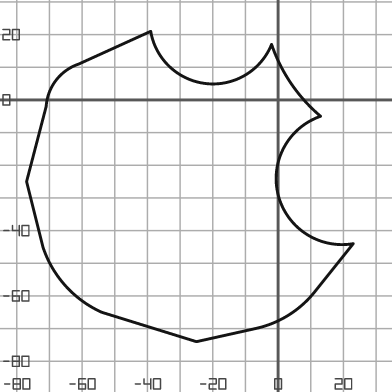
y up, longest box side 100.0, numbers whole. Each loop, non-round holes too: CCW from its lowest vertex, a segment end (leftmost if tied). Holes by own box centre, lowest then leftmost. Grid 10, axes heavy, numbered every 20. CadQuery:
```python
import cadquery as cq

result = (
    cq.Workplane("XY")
    .moveTo(-25.0, -74.0)
    .lineTo(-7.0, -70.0)
    .threePointArc((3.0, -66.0), (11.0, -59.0))
    .lineTo(23.0, -44.0)
    .threePointArc((0.0, -29.0), (13.0, -5.0))
    .threePointArc((4.0, 5.0), (-2.0, 17.0))
    .threePointArc((-22.0, 5.0), (-39.0, 21.0))
    .lineTo(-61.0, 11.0)
    .threePointArc((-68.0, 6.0), (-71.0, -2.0))
    .lineTo(-77.0, -25.0)
    .lineTo(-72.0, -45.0)
    .threePointArc((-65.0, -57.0), (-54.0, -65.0))
    .close()
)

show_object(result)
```